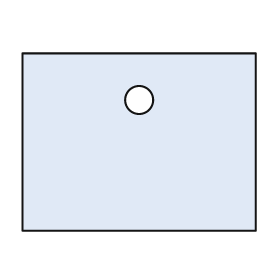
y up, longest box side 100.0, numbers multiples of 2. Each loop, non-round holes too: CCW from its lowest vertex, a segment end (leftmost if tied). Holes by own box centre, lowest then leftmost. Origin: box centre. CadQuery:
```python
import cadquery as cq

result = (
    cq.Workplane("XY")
    .moveTo(-50.0, -38.0)
    .lineTo(50.0, -38.0)
    .lineTo(50.0, 38.0)
    .lineTo(-50.0, 38.0)
    .close()
    .moveTo(0.0, 18.0)
    .circle(6.0)
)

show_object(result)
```